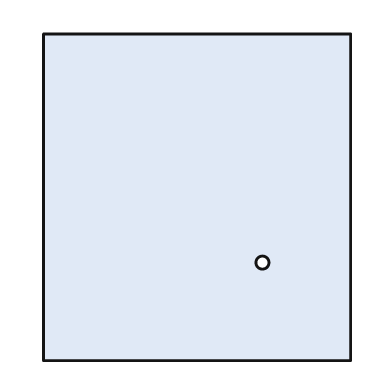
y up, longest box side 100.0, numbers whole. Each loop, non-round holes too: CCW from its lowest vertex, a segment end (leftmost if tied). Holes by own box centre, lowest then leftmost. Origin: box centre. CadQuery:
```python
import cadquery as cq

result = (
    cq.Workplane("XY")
    .moveTo(-47.0, -50.0)
    .lineTo(47.0, -50.0)
    .lineTo(47.0, 50.0)
    .lineTo(-47.0, 50.0)
    .close()
    .moveTo(20.0, -20.0)
    .circle(2.0)
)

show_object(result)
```